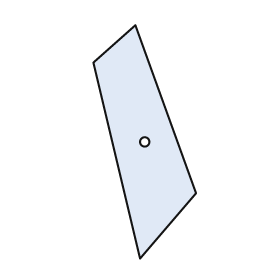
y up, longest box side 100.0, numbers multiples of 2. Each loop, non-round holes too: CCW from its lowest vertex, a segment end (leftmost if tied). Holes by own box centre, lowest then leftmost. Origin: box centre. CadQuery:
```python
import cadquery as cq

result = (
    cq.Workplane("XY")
    .moveTo(-2.0, -50.0)
    .lineTo(22.0, -22.0)
    .lineTo(-4.0, 50.0)
    .lineTo(-22.0, 34.0)
    .close()
    .moveTo(0.0, 0.0)
    .circle(2.0)
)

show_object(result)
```